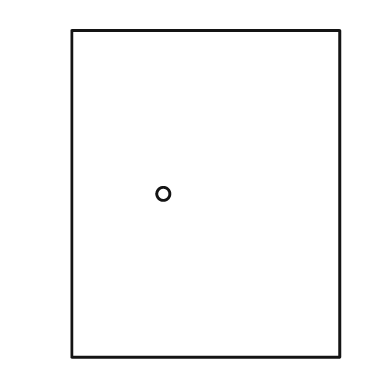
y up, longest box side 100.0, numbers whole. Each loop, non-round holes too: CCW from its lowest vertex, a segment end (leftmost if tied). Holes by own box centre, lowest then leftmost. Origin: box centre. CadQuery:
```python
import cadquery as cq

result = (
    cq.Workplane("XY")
    .moveTo(-41.0, -50.0)
    .lineTo(41.0, -50.0)
    .lineTo(41.0, 50.0)
    .lineTo(-41.0, 50.0)
    .close()
    .moveTo(-13.0, 0.0)
    .circle(2.0)
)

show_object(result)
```